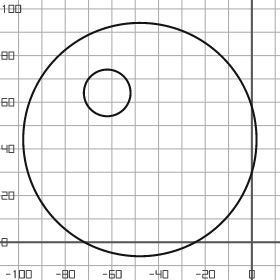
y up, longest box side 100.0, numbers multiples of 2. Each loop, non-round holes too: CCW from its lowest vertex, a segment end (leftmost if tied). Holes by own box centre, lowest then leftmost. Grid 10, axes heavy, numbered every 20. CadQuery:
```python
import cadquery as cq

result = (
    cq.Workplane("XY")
    .moveTo(-48.0, 44.0)
    .circle(50.0)
    .moveTo(-62.0, 64.0)
    .circle(10.0)
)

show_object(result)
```